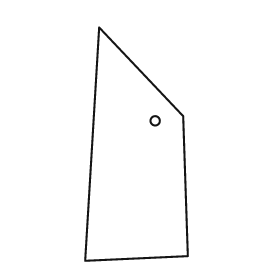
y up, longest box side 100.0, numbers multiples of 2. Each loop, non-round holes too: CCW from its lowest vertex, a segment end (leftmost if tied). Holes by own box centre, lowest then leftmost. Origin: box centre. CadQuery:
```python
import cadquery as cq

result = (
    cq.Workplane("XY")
    .moveTo(-22.0, -50.0)
    .lineTo(22.0, -48.0)
    .lineTo(20.0, 12.0)
    .lineTo(-16.0, 50.0)
    .close()
    .moveTo(8.0, 10.0)
    .circle(2.0)
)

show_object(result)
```